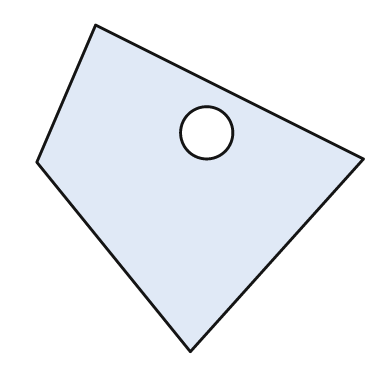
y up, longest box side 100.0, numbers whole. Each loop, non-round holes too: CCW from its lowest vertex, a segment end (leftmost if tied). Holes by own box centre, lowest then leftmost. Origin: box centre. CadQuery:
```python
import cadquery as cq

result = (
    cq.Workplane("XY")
    .moveTo(-3.0, -50.0)
    .lineTo(50.0, 9.0)
    .lineTo(-32.0, 50.0)
    .lineTo(-50.0, 8.0)
    .close()
    .moveTo(2.0, 17.0)
    .circle(8.0)
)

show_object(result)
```